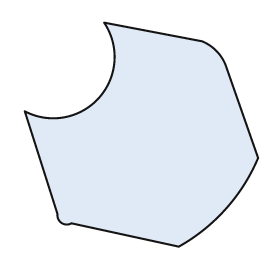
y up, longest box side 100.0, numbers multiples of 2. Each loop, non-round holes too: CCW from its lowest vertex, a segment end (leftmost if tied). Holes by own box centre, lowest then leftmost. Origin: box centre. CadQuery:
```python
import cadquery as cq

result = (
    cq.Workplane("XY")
    .moveTo(16.0, -48.0)
    .threePointArc((36.0, -32.0), (50.0, -10.0))
    .lineTo(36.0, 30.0)
    .threePointArc((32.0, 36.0), (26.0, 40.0))
    .lineTo(-16.0, 48.0)
    .threePointArc((-18.0, 16.0), (-50.0, 10.0))
    .lineTo(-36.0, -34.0)
    .threePointArc((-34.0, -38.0), (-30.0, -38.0))
    .close()
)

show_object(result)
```